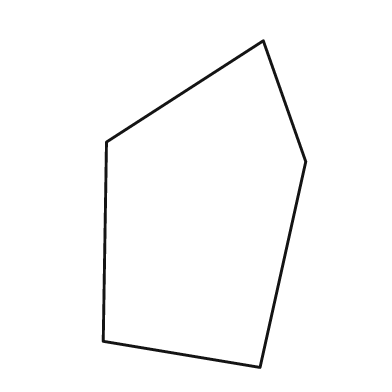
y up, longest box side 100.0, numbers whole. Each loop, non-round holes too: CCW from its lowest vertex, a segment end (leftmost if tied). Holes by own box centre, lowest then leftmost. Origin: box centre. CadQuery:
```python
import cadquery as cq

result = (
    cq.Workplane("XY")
    .moveTo(17.0, -50.0)
    .lineTo(31.0, 13.0)
    .lineTo(18.0, 50.0)
    .lineTo(-30.0, 19.0)
    .lineTo(-31.0, -42.0)
    .close()
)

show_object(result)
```